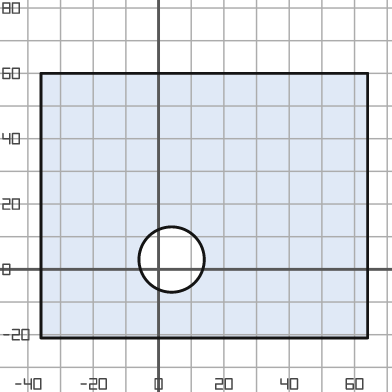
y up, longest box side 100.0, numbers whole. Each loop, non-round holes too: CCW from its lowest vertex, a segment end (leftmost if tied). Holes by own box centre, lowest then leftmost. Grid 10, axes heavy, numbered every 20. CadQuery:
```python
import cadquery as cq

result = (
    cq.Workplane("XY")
    .moveTo(-36.0, -21.0)
    .lineTo(64.0, -21.0)
    .lineTo(64.0, 60.0)
    .lineTo(-36.0, 60.0)
    .close()
    .moveTo(4.0, 3.0)
    .circle(10.0)
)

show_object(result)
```